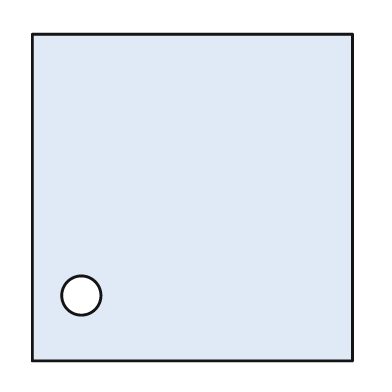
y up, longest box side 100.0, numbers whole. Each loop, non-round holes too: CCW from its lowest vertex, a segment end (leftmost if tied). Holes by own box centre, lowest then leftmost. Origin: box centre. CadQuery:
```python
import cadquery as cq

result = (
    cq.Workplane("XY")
    .moveTo(-49.0, -50.0)
    .lineTo(49.0, -50.0)
    .lineTo(49.0, 50.0)
    .lineTo(-49.0, 50.0)
    .close()
    .moveTo(-34.0, -30.0)
    .circle(6.0)
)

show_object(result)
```